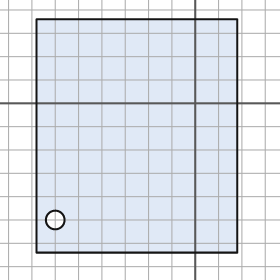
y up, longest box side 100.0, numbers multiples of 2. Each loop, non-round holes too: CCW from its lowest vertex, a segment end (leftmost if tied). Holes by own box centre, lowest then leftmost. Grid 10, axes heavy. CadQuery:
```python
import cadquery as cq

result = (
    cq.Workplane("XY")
    .moveTo(-68.0, -64.0)
    .lineTo(18.0, -64.0)
    .lineTo(18.0, 36.0)
    .lineTo(-68.0, 36.0)
    .close()
    .moveTo(-60.0, -50.0)
    .circle(4.0)
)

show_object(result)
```